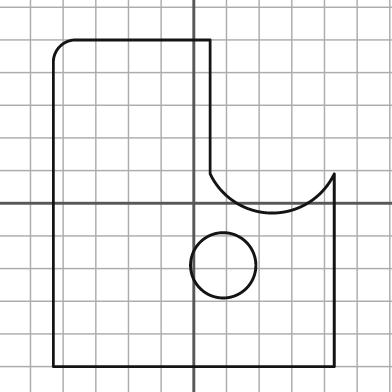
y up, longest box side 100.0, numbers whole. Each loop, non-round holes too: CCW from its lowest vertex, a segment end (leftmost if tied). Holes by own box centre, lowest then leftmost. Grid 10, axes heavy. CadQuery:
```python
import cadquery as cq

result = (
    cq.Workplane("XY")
    .moveTo(-43.0, -50.0)
    .lineTo(43.0, -50.0)
    .lineTo(43.0, 9.0)
    .threePointArc((24.0, -3.0), (5.0, 9.0))
    .lineTo(5.0, 50.0)
    .lineTo(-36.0, 50.0)
    .threePointArc((-41.0, 48.0), (-43.0, 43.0))
    .close()
    .moveTo(9.0, -19.0)
    .circle(10.0)
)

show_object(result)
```